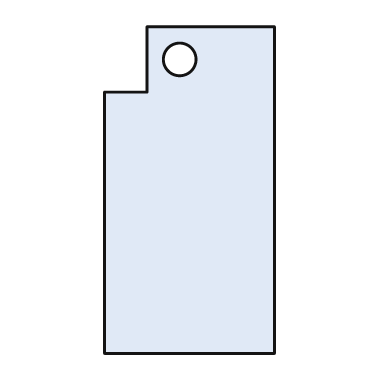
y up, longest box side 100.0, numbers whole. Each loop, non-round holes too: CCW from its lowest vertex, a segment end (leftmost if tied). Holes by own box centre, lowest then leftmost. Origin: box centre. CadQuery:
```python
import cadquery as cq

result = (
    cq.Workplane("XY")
    .moveTo(-26.0, -50.0)
    .lineTo(26.0, -50.0)
    .lineTo(26.0, 50.0)
    .lineTo(-13.0, 50.0)
    .lineTo(-13.0, 30.0)
    .lineTo(-26.0, 30.0)
    .close()
    .moveTo(-3.0, 40.0)
    .circle(5.0)
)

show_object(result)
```